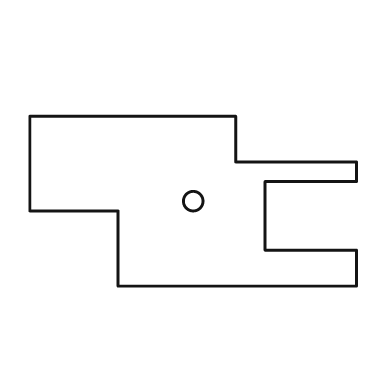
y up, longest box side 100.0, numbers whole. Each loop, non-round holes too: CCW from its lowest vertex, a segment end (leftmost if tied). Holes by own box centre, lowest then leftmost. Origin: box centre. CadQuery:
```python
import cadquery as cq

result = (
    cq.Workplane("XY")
    .moveTo(-23.0, -26.0)
    .lineTo(50.0, -26.0)
    .lineTo(50.0, -15.0)
    .lineTo(22.0, -15.0)
    .lineTo(22.0, 6.0)
    .lineTo(50.0, 6.0)
    .lineTo(50.0, 12.0)
    .lineTo(13.0, 12.0)
    .lineTo(13.0, 26.0)
    .lineTo(-50.0, 26.0)
    .lineTo(-50.0, -3.0)
    .lineTo(-23.0, -3.0)
    .close()
    .moveTo(0.0, 0.0)
    .circle(3.0)
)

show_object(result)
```